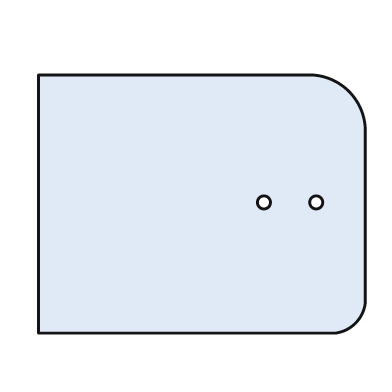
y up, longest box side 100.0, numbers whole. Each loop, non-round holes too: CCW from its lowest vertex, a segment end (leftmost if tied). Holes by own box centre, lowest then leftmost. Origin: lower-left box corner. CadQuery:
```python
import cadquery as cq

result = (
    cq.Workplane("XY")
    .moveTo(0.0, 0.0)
    .lineTo(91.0, 0.0)
    .threePointArc((97.0, 3.0), (100.0, 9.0))
    .lineTo(100.0, 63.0)
    .threePointArc((95.0, 74.0), (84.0, 79.0))
    .lineTo(0.0, 79.0)
    .close()
    .moveTo(69.0, 40.0)
    .circle(2.0)
    .moveTo(85.0, 40.0)
    .circle(2.0)
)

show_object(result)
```